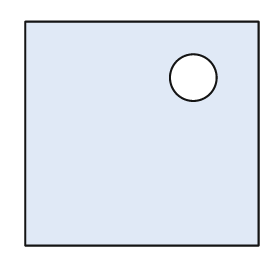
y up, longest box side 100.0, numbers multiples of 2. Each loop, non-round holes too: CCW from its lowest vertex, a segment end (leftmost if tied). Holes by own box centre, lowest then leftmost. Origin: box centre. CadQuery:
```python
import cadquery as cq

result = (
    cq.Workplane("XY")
    .moveTo(-50.0, -48.0)
    .lineTo(50.0, -48.0)
    .lineTo(50.0, 48.0)
    .lineTo(-50.0, 48.0)
    .close()
    .moveTo(22.0, 24.0)
    .circle(10.0)
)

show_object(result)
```